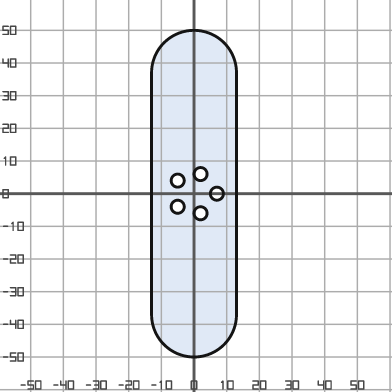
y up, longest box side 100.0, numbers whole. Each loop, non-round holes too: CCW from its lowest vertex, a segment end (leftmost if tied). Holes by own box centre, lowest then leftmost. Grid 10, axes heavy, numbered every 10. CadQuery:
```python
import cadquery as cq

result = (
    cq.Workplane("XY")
    .moveTo(-13.0, -37.0)
    .threePointArc((0.0, -50.0), (13.0, -37.0))
    .lineTo(13.0, 37.0)
    .threePointArc((0.0, 50.0), (-13.0, 37.0))
    .close()
    .moveTo(2.0, -6.0)
    .circle(2.0)
    .moveTo(-5.0, -4.0)
    .circle(2.0)
    .moveTo(7.0, 0.0)
    .circle(2.0)
    .moveTo(-5.0, 4.0)
    .circle(2.0)
    .moveTo(2.0, 6.0)
    .circle(2.0)
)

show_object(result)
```